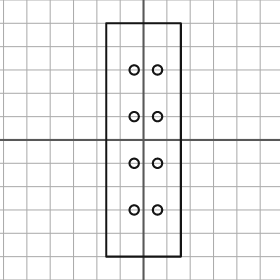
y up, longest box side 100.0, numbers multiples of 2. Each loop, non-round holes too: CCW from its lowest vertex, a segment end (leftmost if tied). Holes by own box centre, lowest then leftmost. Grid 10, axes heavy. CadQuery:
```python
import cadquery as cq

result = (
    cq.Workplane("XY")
    .moveTo(-16.0, -50.0)
    .lineTo(16.0, -50.0)
    .lineTo(16.0, 50.0)
    .lineTo(-16.0, 50.0)
    .close()
    .moveTo(-4.0, -30.0)
    .circle(2.0)
    .moveTo(6.0, -30.0)
    .circle(2.0)
    .moveTo(-4.0, -10.0)
    .circle(2.0)
    .moveTo(6.0, -10.0)
    .circle(2.0)
    .moveTo(-4.0, 10.0)
    .circle(2.0)
    .moveTo(6.0, 10.0)
    .circle(2.0)
    .moveTo(-4.0, 30.0)
    .circle(2.0)
    .moveTo(6.0, 30.0)
    .circle(2.0)
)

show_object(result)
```